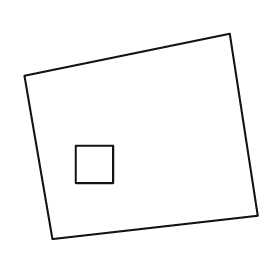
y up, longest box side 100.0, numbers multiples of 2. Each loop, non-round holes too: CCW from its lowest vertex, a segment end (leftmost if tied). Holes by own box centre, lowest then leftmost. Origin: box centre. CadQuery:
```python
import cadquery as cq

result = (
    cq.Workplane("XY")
    .moveTo(-38.0, -44.0)
    .lineTo(50.0, -34.0)
    .lineTo(38.0, 44.0)
    .lineTo(-50.0, 26.0)
    .close()
    .moveTo(-28.0, -20.0)
    .lineTo(-12.0, -20.0)
    .lineTo(-12.0, -4.0)
    .lineTo(-28.0, -4.0)
    .close()
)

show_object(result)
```